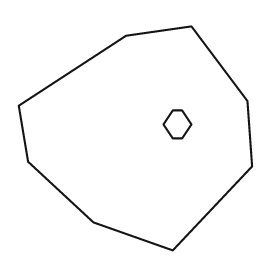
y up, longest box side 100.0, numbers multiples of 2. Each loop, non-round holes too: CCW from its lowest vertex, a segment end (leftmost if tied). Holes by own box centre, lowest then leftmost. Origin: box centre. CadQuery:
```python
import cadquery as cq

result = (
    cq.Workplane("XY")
    .moveTo(16.0, -48.0)
    .lineTo(50.0, -12.0)
    .lineTo(48.0, 16.0)
    .lineTo(24.0, 48.0)
    .lineTo(-4.0, 44.0)
    .lineTo(-50.0, 14.0)
    .lineTo(-46.0, -10.0)
    .lineTo(-18.0, -36.0)
    .close()
    .moveTo(16.0, 0.0)
    .lineTo(20.0, 0.0)
    .lineTo(24.0, 6.0)
    .lineTo(20.0, 12.0)
    .lineTo(16.0, 12.0)
    .lineTo(12.0, 6.0)
    .close()
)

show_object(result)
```